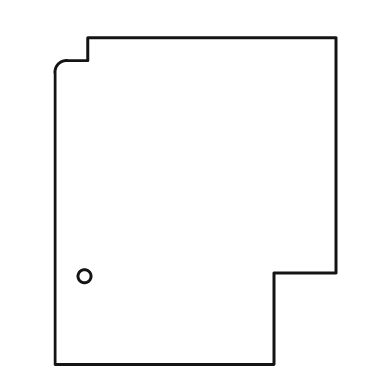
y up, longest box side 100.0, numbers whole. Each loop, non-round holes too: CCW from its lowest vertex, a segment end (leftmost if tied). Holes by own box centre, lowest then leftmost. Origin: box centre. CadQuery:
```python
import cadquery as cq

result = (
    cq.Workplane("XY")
    .moveTo(-43.0, -50.0)
    .lineTo(24.0, -50.0)
    .lineTo(24.0, -22.0)
    .lineTo(43.0, -22.0)
    .lineTo(43.0, 50.0)
    .lineTo(-33.0, 50.0)
    .lineTo(-33.0, 43.0)
    .lineTo(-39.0, 43.0)
    .threePointArc((-42.0, 42.0), (-43.0, 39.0))
    .close()
    .moveTo(-34.0, -23.0)
    .circle(2.0)
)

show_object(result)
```